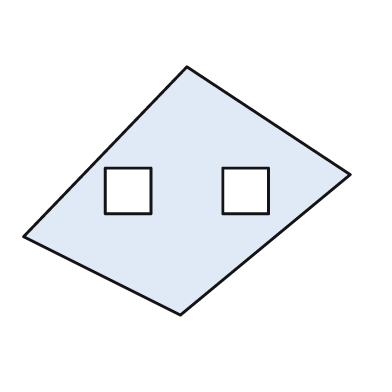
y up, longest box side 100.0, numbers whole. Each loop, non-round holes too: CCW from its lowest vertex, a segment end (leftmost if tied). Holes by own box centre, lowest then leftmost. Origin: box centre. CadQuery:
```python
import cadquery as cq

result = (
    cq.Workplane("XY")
    .moveTo(-2.0, -38.0)
    .lineTo(50.0, 5.0)
    .lineTo(0.0, 38.0)
    .lineTo(-50.0, -14.0)
    .close()
    .moveTo(-25.0, -7.0)
    .lineTo(-11.0, -7.0)
    .lineTo(-11.0, 7.0)
    .lineTo(-25.0, 7.0)
    .close()
    .moveTo(11.0, -7.0)
    .lineTo(25.0, -7.0)
    .lineTo(25.0, 7.0)
    .lineTo(11.0, 7.0)
    .close()
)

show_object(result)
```